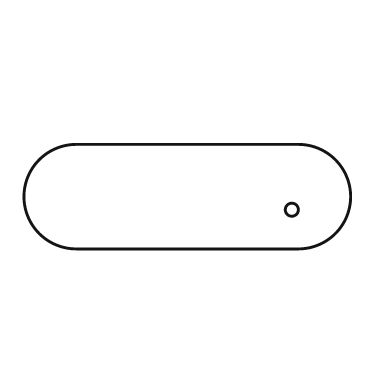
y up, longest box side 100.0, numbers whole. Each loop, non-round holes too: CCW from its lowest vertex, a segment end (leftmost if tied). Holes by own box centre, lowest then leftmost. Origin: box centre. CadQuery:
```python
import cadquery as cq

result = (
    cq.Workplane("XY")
    .moveTo(-34.0, -16.0)
    .lineTo(34.0, -16.0)
    .threePointArc((50.0, 0.0), (34.0, 16.0))
    .lineTo(-34.0, 16.0)
    .threePointArc((-50.0, 0.0), (-34.0, -16.0))
    .close()
    .moveTo(32.0, -4.0)
    .circle(2.0)
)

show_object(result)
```